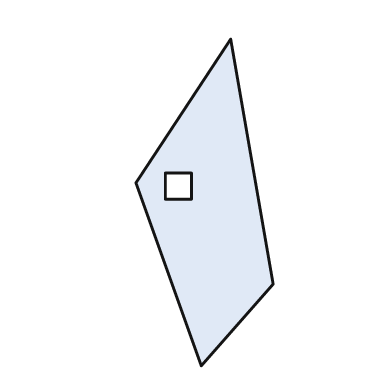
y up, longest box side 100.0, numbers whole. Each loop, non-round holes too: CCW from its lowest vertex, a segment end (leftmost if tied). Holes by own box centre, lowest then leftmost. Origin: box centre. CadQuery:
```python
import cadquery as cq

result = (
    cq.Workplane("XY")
    .moveTo(-1.0, -50.0)
    .lineTo(21.0, -25.0)
    .lineTo(8.0, 50.0)
    .lineTo(-21.0, 6.0)
    .close()
    .moveTo(-12.0, 1.0)
    .lineTo(-4.0, 1.0)
    .lineTo(-4.0, 9.0)
    .lineTo(-12.0, 9.0)
    .close()
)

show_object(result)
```